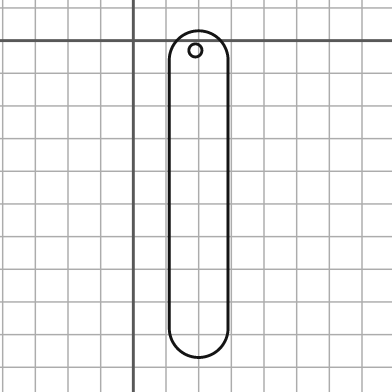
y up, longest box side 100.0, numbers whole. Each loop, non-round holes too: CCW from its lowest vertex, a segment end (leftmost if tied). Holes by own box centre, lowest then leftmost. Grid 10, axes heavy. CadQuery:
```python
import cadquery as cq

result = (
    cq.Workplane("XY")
    .moveTo(11.0, -88.0)
    .threePointArc((20.0, -97.0), (29.0, -88.0))
    .lineTo(29.0, -6.0)
    .threePointArc((20.0, 3.0), (11.0, -6.0))
    .close()
    .moveTo(19.0, -3.0)
    .circle(2.0)
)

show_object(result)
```